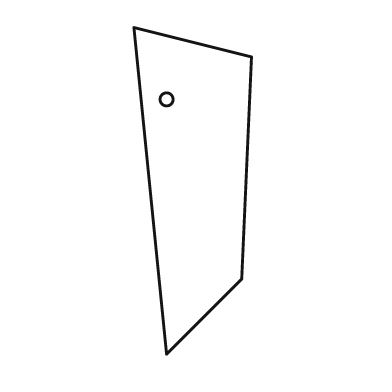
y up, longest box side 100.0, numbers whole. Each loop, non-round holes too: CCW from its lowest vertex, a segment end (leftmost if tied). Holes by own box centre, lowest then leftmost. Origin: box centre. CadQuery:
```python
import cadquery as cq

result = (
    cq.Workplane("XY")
    .moveTo(-8.0, -50.0)
    .lineTo(15.0, -27.0)
    .lineTo(18.0, 41.0)
    .lineTo(-18.0, 50.0)
    .close()
    .moveTo(-8.0, 28.0)
    .circle(2.0)
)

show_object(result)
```